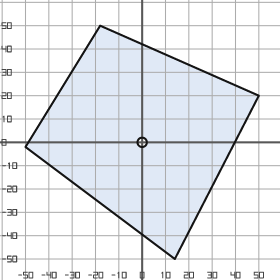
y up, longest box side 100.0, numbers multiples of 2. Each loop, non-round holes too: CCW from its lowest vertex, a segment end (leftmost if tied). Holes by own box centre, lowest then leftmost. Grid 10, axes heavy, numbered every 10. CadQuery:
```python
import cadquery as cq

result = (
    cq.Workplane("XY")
    .moveTo(14.0, -50.0)
    .lineTo(50.0, 20.0)
    .lineTo(-18.0, 50.0)
    .lineTo(-50.0, -2.0)
    .close()
    .moveTo(0.0, 0.0)
    .circle(2.0)
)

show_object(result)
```